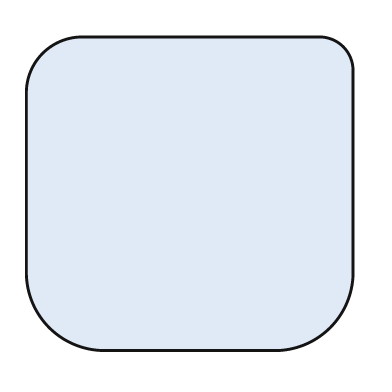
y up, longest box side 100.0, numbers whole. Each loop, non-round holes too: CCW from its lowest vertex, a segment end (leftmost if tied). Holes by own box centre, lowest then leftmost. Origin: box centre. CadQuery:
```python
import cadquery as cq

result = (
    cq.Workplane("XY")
    .moveTo(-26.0, -48.0)
    .lineTo(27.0, -48.0)
    .threePointArc((43.0, -41.0), (50.0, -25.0))
    .lineTo(50.0, 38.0)
    .threePointArc((47.0, 45.0), (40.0, 48.0))
    .lineTo(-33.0, 48.0)
    .threePointArc((-45.0, 43.0), (-50.0, 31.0))
    .lineTo(-50.0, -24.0)
    .threePointArc((-43.0, -41.0), (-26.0, -48.0))
    .close()
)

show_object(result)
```